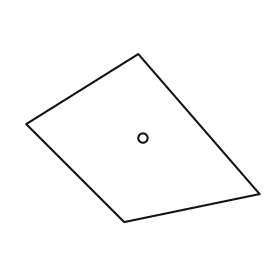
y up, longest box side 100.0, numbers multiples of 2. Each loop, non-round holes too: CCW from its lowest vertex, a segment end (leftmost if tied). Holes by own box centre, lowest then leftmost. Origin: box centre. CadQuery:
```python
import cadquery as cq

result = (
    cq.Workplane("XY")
    .moveTo(-8.0, -36.0)
    .lineTo(50.0, -24.0)
    .lineTo(-2.0, 36.0)
    .lineTo(-50.0, 6.0)
    .close()
    .moveTo(0.0, 0.0)
    .circle(2.0)
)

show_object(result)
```